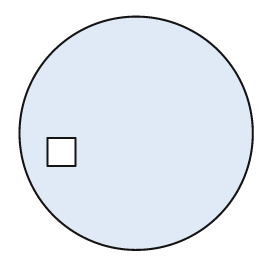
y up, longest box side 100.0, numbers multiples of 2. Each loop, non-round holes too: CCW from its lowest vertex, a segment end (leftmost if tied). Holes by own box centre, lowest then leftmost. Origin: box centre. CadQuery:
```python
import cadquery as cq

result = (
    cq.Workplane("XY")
    .moveTo(0.0, 0.0)
    .circle(50.0)
    .moveTo(-38.0, -14.0)
    .lineTo(-26.0, -14.0)
    .lineTo(-26.0, -2.0)
    .lineTo(-38.0, -2.0)
    .close()
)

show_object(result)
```